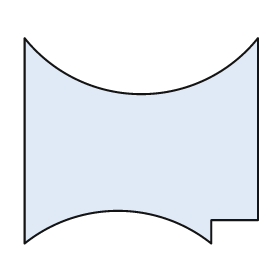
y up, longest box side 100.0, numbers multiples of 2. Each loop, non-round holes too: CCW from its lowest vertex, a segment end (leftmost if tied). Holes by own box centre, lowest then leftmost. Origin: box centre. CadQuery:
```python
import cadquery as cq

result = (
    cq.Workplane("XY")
    .moveTo(-50.0, -44.0)
    .threePointArc((-10.0, -30.0), (30.0, -44.0))
    .lineTo(30.0, -34.0)
    .lineTo(50.0, -34.0)
    .lineTo(50.0, 44.0)
    .threePointArc((0.0, 20.0), (-50.0, 44.0))
    .close()
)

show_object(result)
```